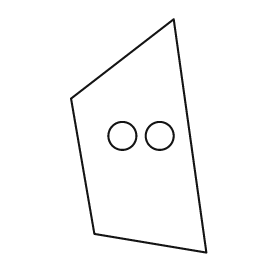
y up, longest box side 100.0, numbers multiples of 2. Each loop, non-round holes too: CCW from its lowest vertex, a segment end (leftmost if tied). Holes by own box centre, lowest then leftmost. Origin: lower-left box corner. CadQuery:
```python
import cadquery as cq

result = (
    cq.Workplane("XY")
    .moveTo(58.0, 0.0)
    .lineTo(44.0, 100.0)
    .lineTo(0.0, 66.0)
    .lineTo(10.0, 8.0)
    .close()
    .moveTo(22.0, 50.0)
    .circle(6.0)
    .moveTo(38.0, 50.0)
    .circle(6.0)
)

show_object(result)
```